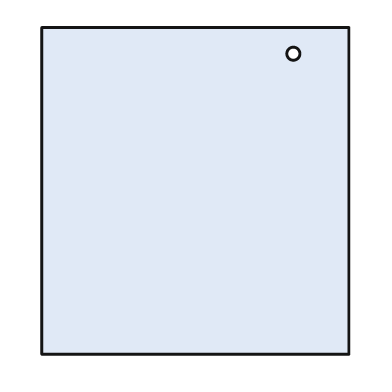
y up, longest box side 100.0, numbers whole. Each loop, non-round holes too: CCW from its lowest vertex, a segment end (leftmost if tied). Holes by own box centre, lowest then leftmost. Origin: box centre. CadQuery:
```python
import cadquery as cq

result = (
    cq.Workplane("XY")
    .moveTo(-47.0, -50.0)
    .lineTo(47.0, -50.0)
    .lineTo(47.0, 50.0)
    .lineTo(-47.0, 50.0)
    .close()
    .moveTo(30.0, 42.0)
    .circle(2.0)
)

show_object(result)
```